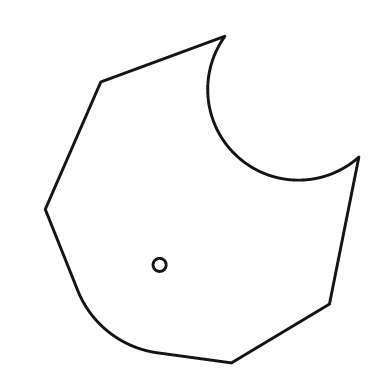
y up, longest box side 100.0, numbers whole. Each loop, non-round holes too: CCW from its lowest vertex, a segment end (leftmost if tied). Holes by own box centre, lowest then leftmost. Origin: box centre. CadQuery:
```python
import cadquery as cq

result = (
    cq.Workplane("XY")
    .moveTo(9.0, -50.0)
    .lineTo(39.0, -32.0)
    .lineTo(48.0, 13.0)
    .threePointArc((11.0, 13.0), (7.0, 50.0))
    .lineTo(-31.0, 36.0)
    .lineTo(-48.0, -3.0)
    .lineTo(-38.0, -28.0)
    .threePointArc((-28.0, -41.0), (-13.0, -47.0))
    .close()
    .moveTo(-13.0, -20.0)
    .circle(2.0)
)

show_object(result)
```